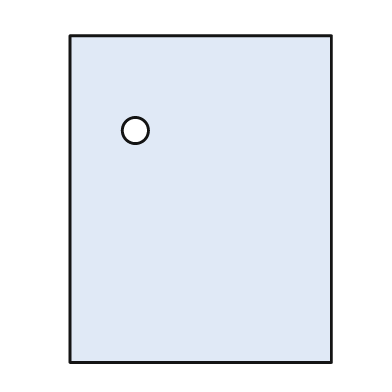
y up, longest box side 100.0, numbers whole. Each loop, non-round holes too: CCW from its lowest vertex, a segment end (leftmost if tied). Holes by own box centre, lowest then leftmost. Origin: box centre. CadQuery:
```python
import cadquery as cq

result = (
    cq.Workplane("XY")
    .moveTo(-40.0, -50.0)
    .lineTo(40.0, -50.0)
    .lineTo(40.0, 50.0)
    .lineTo(-40.0, 50.0)
    .close()
    .moveTo(-20.0, 21.0)
    .circle(4.0)
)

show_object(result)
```